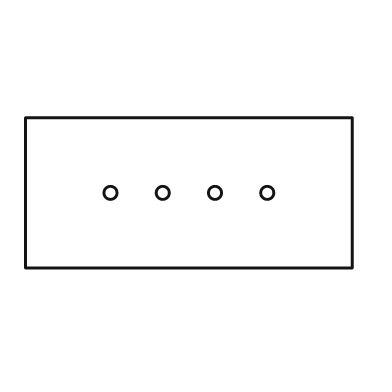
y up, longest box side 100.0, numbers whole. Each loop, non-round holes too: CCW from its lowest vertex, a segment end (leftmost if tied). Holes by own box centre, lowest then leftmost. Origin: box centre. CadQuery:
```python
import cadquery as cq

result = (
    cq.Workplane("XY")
    .moveTo(-50.0, -23.0)
    .lineTo(50.0, -23.0)
    .lineTo(50.0, 23.0)
    .lineTo(-50.0, 23.0)
    .close()
    .moveTo(-24.0, 0.0)
    .circle(2.0)
    .moveTo(-8.0, 0.0)
    .circle(2.0)
    .moveTo(8.0, 0.0)
    .circle(2.0)
    .moveTo(24.0, 0.0)
    .circle(2.0)
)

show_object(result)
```